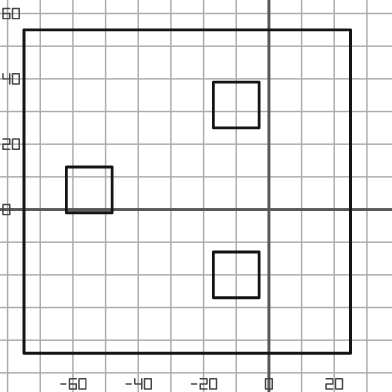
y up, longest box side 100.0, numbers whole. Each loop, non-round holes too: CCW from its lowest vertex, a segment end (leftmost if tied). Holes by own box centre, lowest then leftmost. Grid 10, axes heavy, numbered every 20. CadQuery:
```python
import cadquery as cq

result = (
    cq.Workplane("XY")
    .moveTo(-75.0, -44.0)
    .lineTo(25.0, -44.0)
    .lineTo(25.0, 55.0)
    .lineTo(-75.0, 55.0)
    .close()
    .moveTo(-17.0, -27.0)
    .lineTo(-3.0, -27.0)
    .lineTo(-3.0, -13.0)
    .lineTo(-17.0, -13.0)
    .close()
    .moveTo(-62.0, -1.0)
    .lineTo(-48.0, -1.0)
    .lineTo(-48.0, 13.0)
    .lineTo(-62.0, 13.0)
    .close()
    .moveTo(-17.0, 25.0)
    .lineTo(-3.0, 25.0)
    .lineTo(-3.0, 39.0)
    .lineTo(-17.0, 39.0)
    .close()
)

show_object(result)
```